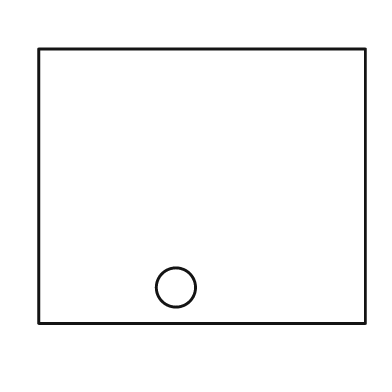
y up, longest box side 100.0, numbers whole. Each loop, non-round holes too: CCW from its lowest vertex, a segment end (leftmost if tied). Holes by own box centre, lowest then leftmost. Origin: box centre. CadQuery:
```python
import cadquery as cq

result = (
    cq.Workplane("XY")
    .moveTo(-50.0, -42.0)
    .lineTo(50.0, -42.0)
    .lineTo(50.0, 42.0)
    .lineTo(-50.0, 42.0)
    .close()
    .moveTo(-8.0, -31.0)
    .circle(6.0)
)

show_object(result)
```